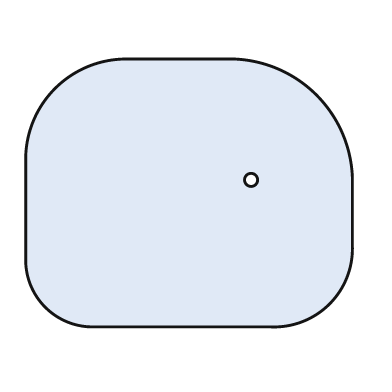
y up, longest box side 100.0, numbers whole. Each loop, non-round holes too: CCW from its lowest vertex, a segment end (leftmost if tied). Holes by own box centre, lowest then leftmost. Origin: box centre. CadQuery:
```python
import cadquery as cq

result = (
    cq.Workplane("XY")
    .moveTo(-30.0, -41.0)
    .lineTo(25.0, -41.0)
    .threePointArc((43.0, -34.0), (50.0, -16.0))
    .lineTo(50.0, 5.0)
    .threePointArc((39.0, 30.0), (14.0, 41.0))
    .lineTo(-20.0, 41.0)
    .threePointArc((-41.0, 32.0), (-50.0, 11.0))
    .lineTo(-50.0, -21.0)
    .threePointArc((-44.0, -35.0), (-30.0, -41.0))
    .close()
    .moveTo(19.0, 4.0)
    .circle(2.0)
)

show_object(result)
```